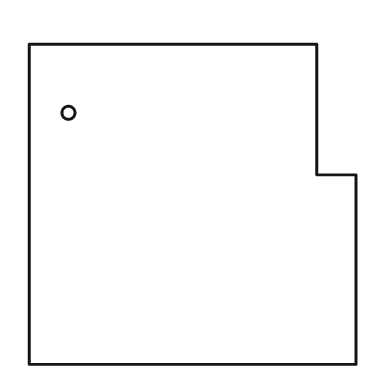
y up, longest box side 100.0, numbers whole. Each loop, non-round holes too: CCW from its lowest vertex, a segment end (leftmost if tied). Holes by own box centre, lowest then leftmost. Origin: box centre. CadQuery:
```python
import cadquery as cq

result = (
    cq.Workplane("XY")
    .moveTo(-50.0, -49.0)
    .lineTo(50.0, -49.0)
    .lineTo(50.0, 9.0)
    .lineTo(38.0, 9.0)
    .lineTo(38.0, 49.0)
    .lineTo(-50.0, 49.0)
    .close()
    .moveTo(-38.0, 28.0)
    .circle(2.0)
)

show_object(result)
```